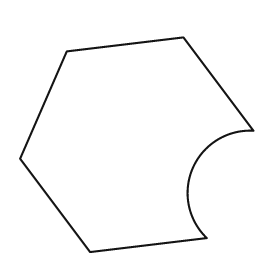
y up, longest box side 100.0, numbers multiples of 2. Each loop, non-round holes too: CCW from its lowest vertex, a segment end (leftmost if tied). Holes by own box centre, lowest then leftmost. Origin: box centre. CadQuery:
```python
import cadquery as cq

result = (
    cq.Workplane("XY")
    .moveTo(-20.0, -46.0)
    .lineTo(30.0, -40.0)
    .threePointArc((24.0, -10.0), (50.0, 6.0))
    .lineTo(20.0, 46.0)
    .lineTo(-30.0, 40.0)
    .lineTo(-50.0, -6.0)
    .close()
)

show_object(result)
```